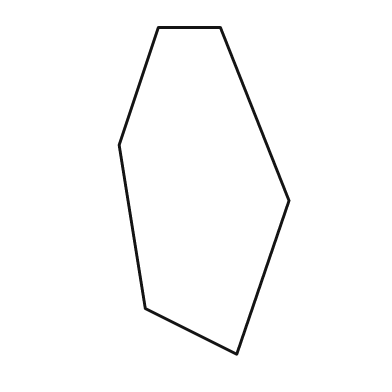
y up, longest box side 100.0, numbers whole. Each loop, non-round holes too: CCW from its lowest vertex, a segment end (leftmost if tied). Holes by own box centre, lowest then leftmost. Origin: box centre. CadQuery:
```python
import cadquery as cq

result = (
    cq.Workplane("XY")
    .moveTo(10.0, -50.0)
    .lineTo(26.0, -3.0)
    .lineTo(5.0, 50.0)
    .lineTo(-14.0, 50.0)
    .lineTo(-26.0, 14.0)
    .lineTo(-18.0, -36.0)
    .close()
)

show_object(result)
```